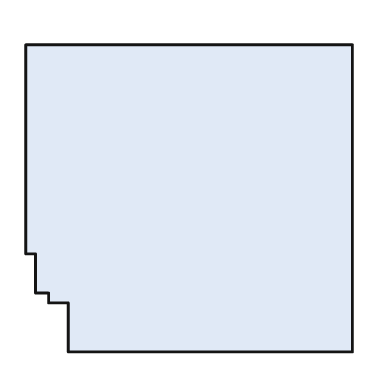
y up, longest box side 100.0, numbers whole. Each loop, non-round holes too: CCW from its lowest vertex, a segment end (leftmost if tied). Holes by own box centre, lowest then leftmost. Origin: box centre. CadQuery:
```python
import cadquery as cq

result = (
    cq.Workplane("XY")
    .moveTo(-37.0, -47.0)
    .lineTo(50.0, -47.0)
    .lineTo(50.0, 47.0)
    .lineTo(-50.0, 47.0)
    .lineTo(-50.0, -17.0)
    .lineTo(-47.0, -17.0)
    .lineTo(-47.0, -29.0)
    .lineTo(-43.0, -29.0)
    .lineTo(-43.0, -32.0)
    .lineTo(-37.0, -32.0)
    .close()
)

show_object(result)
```